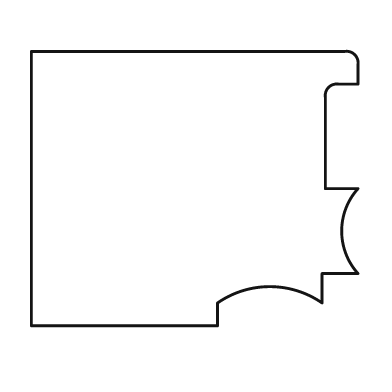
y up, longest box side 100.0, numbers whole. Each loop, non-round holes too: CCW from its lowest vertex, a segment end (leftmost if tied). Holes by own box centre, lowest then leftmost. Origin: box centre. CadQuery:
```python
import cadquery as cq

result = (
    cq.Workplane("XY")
    .moveTo(-50.0, -42.0)
    .lineTo(7.0, -42.0)
    .lineTo(7.0, -35.0)
    .threePointArc((23.0, -30.0), (39.0, -35.0))
    .lineTo(39.0, -26.0)
    .lineTo(50.0, -26.0)
    .threePointArc((45.0, -13.0), (50.0, 0.0))
    .lineTo(40.0, 0.0)
    .lineTo(40.0, 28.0)
    .threePointArc((41.0, 31.0), (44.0, 32.0))
    .lineTo(50.0, 32.0)
    .lineTo(50.0, 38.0)
    .threePointArc((49.0, 41.0), (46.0, 42.0))
    .lineTo(-50.0, 42.0)
    .close()
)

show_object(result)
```